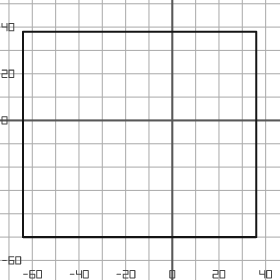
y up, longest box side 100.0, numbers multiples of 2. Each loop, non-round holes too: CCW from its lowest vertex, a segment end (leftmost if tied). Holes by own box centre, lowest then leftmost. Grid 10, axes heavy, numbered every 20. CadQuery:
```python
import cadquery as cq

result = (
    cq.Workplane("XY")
    .moveTo(-64.0, -50.0)
    .lineTo(36.0, -50.0)
    .lineTo(36.0, 38.0)
    .lineTo(-64.0, 38.0)
    .close()
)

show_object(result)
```